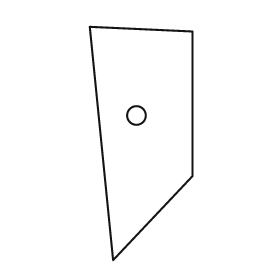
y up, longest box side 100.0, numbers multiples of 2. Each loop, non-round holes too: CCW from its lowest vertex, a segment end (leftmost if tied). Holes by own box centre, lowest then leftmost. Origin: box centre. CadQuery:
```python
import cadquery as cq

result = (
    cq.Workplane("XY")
    .moveTo(-12.0, -50.0)
    .lineTo(22.0, -14.0)
    .lineTo(22.0, 48.0)
    .lineTo(-22.0, 50.0)
    .close()
    .moveTo(-2.0, 12.0)
    .circle(4.0)
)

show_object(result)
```